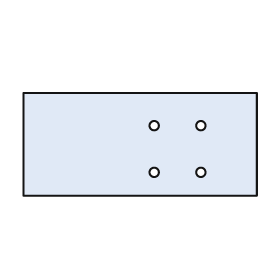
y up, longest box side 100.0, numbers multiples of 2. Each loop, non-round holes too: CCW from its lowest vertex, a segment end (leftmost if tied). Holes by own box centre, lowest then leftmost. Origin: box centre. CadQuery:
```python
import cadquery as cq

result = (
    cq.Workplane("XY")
    .moveTo(-50.0, -22.0)
    .lineTo(50.0, -22.0)
    .lineTo(50.0, 22.0)
    .lineTo(-50.0, 22.0)
    .close()
    .moveTo(6.0, -12.0)
    .circle(2.0)
    .moveTo(26.0, -12.0)
    .circle(2.0)
    .moveTo(6.0, 8.0)
    .circle(2.0)
    .moveTo(26.0, 8.0)
    .circle(2.0)
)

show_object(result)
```